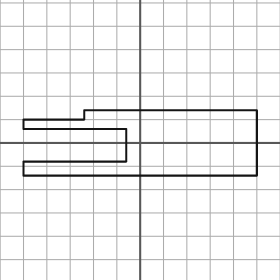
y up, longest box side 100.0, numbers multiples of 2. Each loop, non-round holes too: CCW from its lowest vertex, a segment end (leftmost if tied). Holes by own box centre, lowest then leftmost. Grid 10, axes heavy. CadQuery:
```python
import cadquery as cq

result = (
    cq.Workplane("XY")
    .moveTo(-50.0, -14.0)
    .lineTo(50.0, -14.0)
    .lineTo(50.0, 14.0)
    .lineTo(-24.0, 14.0)
    .lineTo(-24.0, 10.0)
    .lineTo(-50.0, 10.0)
    .lineTo(-50.0, 6.0)
    .lineTo(-6.0, 6.0)
    .lineTo(-6.0, -8.0)
    .lineTo(-50.0, -8.0)
    .close()
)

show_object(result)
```